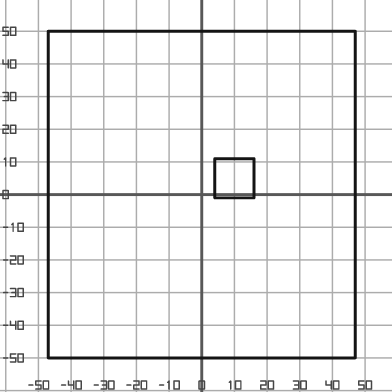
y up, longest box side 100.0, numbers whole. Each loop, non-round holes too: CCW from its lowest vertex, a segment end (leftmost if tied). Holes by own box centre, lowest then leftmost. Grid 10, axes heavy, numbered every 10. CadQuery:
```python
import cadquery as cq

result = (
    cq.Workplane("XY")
    .moveTo(-47.0, -50.0)
    .lineTo(47.0, -50.0)
    .lineTo(47.0, 50.0)
    .lineTo(-47.0, 50.0)
    .close()
    .moveTo(4.0, -1.0)
    .lineTo(16.0, -1.0)
    .lineTo(16.0, 11.0)
    .lineTo(4.0, 11.0)
    .close()
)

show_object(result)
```